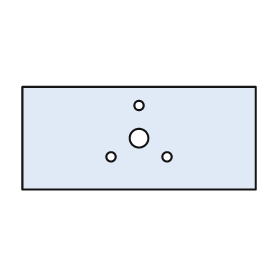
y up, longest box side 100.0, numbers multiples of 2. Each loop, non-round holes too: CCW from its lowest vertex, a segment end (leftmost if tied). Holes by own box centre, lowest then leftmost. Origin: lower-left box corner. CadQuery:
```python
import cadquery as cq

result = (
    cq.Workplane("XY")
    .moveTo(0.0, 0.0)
    .lineTo(100.0, 0.0)
    .lineTo(100.0, 44.0)
    .lineTo(0.0, 44.0)
    .close()
    .moveTo(38.0, 14.0)
    .circle(2.0)
    .moveTo(62.0, 14.0)
    .circle(2.0)
    .moveTo(50.0, 22.0)
    .circle(4.0)
    .moveTo(50.0, 36.0)
    .circle(2.0)
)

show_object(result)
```